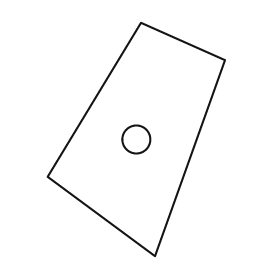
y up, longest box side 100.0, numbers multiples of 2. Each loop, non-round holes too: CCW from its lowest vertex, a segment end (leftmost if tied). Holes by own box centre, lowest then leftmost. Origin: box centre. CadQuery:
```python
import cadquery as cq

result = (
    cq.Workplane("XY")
    .moveTo(8.0, -50.0)
    .lineTo(38.0, 34.0)
    .lineTo(2.0, 50.0)
    .lineTo(-38.0, -16.0)
    .close()
    .moveTo(0.0, 0.0)
    .circle(6.0)
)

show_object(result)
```